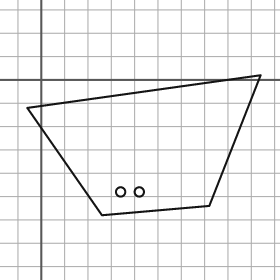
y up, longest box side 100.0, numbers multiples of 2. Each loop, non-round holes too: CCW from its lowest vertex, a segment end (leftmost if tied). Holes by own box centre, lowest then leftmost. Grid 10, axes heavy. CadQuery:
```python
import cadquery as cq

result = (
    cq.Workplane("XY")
    .moveTo(26.0, -58.0)
    .lineTo(72.0, -54.0)
    .lineTo(94.0, 2.0)
    .lineTo(-6.0, -12.0)
    .close()
    .moveTo(34.0, -48.0)
    .circle(2.0)
    .moveTo(42.0, -48.0)
    .circle(2.0)
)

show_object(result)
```